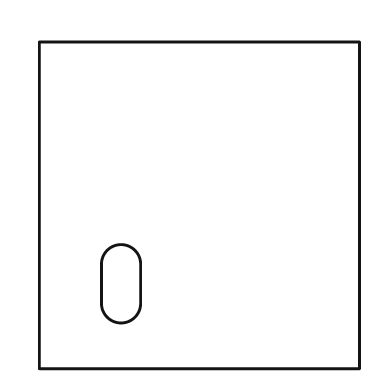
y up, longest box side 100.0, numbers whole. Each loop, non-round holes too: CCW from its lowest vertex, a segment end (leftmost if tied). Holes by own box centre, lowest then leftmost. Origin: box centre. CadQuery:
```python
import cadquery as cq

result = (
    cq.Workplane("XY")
    .moveTo(-49.0, -50.0)
    .lineTo(49.0, -50.0)
    .lineTo(49.0, 50.0)
    .lineTo(-49.0, 50.0)
    .close()
    .moveTo(-30.0, -30.0)
    .threePointArc((-24.0, -36.0), (-18.0, -30.0))
    .lineTo(-18.0, -18.0)
    .threePointArc((-24.0, -12.0), (-30.0, -18.0))
    .close()
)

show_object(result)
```